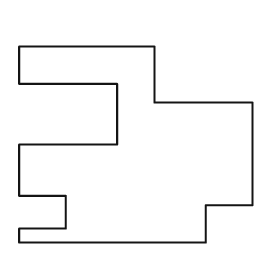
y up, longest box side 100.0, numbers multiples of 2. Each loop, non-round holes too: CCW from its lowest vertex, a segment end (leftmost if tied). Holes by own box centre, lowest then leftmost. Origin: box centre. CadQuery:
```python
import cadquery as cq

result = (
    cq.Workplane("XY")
    .moveTo(-50.0, -42.0)
    .lineTo(30.0, -42.0)
    .lineTo(30.0, -26.0)
    .lineTo(50.0, -26.0)
    .lineTo(50.0, 18.0)
    .lineTo(8.0, 18.0)
    .lineTo(8.0, 42.0)
    .lineTo(-50.0, 42.0)
    .lineTo(-50.0, 26.0)
    .lineTo(-8.0, 26.0)
    .lineTo(-8.0, 0.0)
    .lineTo(-50.0, 0.0)
    .lineTo(-50.0, -22.0)
    .lineTo(-30.0, -22.0)
    .lineTo(-30.0, -36.0)
    .lineTo(-50.0, -36.0)
    .close()
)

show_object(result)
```